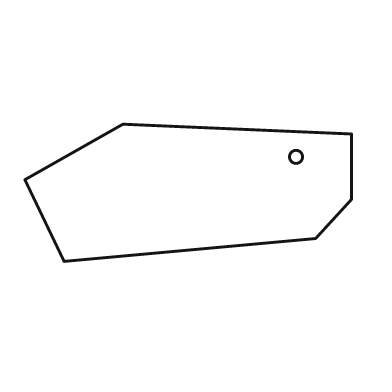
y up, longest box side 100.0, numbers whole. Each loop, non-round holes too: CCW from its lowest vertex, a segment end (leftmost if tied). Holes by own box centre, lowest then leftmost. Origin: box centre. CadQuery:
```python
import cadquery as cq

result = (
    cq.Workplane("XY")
    .moveTo(-38.0, -21.0)
    .lineTo(39.0, -14.0)
    .lineTo(50.0, -2.0)
    .lineTo(50.0, 18.0)
    .lineTo(-20.0, 21.0)
    .lineTo(-50.0, 4.0)
    .close()
    .moveTo(33.0, 11.0)
    .circle(2.0)
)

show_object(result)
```